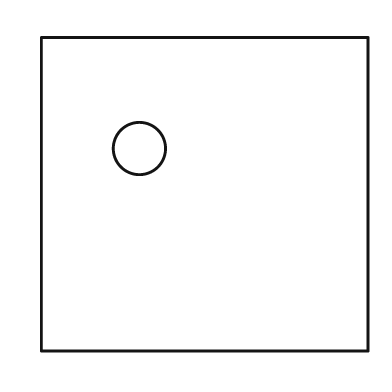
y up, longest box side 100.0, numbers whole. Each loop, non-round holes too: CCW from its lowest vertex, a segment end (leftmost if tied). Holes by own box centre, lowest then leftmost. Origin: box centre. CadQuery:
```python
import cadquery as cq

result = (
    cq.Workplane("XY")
    .moveTo(-50.0, -48.0)
    .lineTo(50.0, -48.0)
    .lineTo(50.0, 48.0)
    .lineTo(-50.0, 48.0)
    .close()
    .moveTo(-20.0, 14.0)
    .circle(8.0)
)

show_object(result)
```